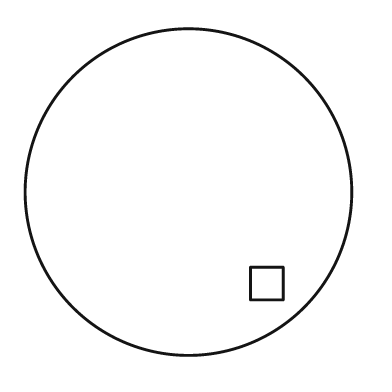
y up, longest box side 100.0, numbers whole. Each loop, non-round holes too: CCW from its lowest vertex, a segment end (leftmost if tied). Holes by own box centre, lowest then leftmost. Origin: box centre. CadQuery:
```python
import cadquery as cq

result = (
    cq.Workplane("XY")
    .moveTo(0.0, 0.0)
    .circle(50.0)
    .moveTo(19.0, -33.0)
    .lineTo(29.0, -33.0)
    .lineTo(29.0, -23.0)
    .lineTo(19.0, -23.0)
    .close()
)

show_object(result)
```